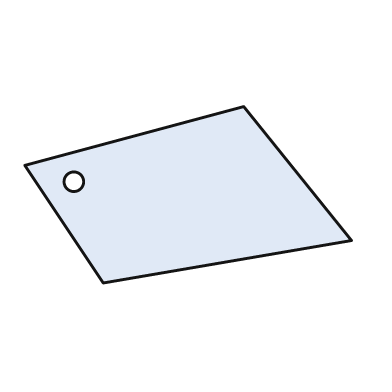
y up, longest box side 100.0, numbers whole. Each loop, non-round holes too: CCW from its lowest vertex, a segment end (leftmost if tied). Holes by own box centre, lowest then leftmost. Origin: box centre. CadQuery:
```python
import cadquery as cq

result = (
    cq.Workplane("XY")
    .moveTo(-26.0, -27.0)
    .lineTo(50.0, -14.0)
    .lineTo(17.0, 27.0)
    .lineTo(-50.0, 9.0)
    .close()
    .moveTo(-35.0, 4.0)
    .circle(3.0)
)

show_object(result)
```